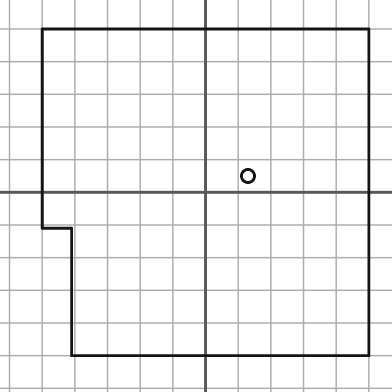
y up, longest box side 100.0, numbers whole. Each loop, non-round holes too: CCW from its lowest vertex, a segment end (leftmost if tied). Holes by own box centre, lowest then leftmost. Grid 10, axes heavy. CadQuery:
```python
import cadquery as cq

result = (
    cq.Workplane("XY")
    .moveTo(-41.0, -50.0)
    .lineTo(50.0, -50.0)
    .lineTo(50.0, 50.0)
    .lineTo(-50.0, 50.0)
    .lineTo(-50.0, -11.0)
    .lineTo(-41.0, -11.0)
    .close()
    .moveTo(13.0, 5.0)
    .circle(2.0)
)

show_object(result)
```